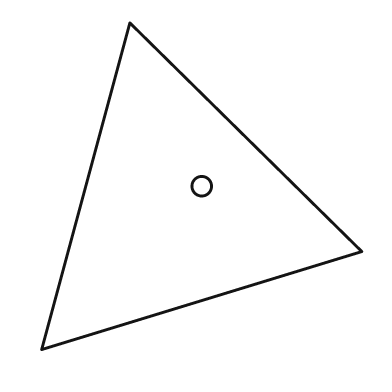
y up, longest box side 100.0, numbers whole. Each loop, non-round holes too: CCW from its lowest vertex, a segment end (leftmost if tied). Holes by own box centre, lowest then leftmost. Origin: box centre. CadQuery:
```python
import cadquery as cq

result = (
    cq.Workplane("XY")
    .moveTo(-49.0, -50.0)
    .lineTo(49.0, -20.0)
    .lineTo(-22.0, 50.0)
    .close()
    .moveTo(0.0, 0.0)
    .circle(3.0)
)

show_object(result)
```